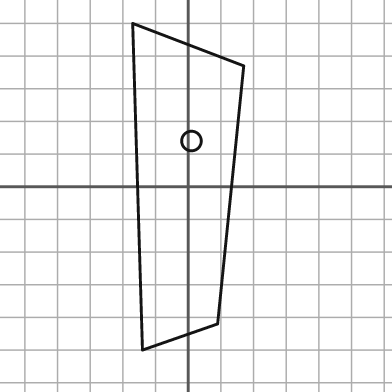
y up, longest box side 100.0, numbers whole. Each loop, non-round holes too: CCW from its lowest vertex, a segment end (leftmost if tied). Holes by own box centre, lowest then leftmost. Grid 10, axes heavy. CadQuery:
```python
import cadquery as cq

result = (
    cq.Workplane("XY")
    .moveTo(-14.0, -50.0)
    .lineTo(9.0, -42.0)
    .lineTo(17.0, 37.0)
    .lineTo(-17.0, 50.0)
    .close()
    .moveTo(1.0, 14.0)
    .circle(3.0)
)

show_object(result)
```